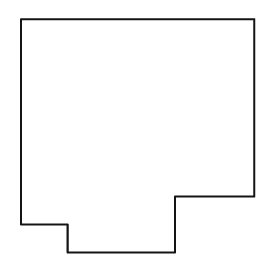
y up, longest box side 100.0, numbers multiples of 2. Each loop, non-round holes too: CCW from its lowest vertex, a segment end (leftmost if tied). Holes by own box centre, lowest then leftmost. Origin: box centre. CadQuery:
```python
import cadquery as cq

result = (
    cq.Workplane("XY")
    .moveTo(-30.0, -50.0)
    .lineTo(16.0, -50.0)
    .lineTo(16.0, -26.0)
    .lineTo(50.0, -26.0)
    .lineTo(50.0, 50.0)
    .lineTo(-50.0, 50.0)
    .lineTo(-50.0, -38.0)
    .lineTo(-30.0, -38.0)
    .close()
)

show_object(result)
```